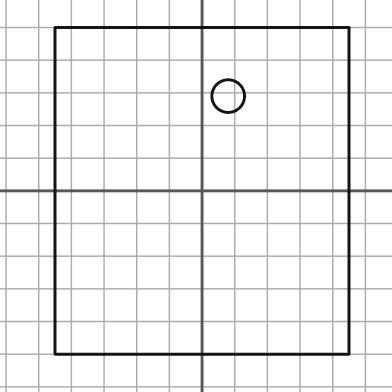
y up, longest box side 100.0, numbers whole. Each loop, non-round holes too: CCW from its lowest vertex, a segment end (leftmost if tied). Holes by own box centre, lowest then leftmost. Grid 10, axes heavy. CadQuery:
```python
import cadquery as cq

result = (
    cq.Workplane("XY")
    .moveTo(-45.0, -50.0)
    .lineTo(45.0, -50.0)
    .lineTo(45.0, 50.0)
    .lineTo(-45.0, 50.0)
    .close()
    .moveTo(8.0, 29.0)
    .circle(5.0)
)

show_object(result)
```